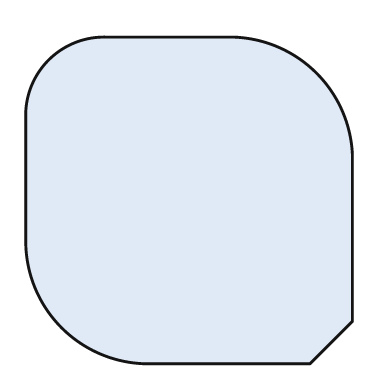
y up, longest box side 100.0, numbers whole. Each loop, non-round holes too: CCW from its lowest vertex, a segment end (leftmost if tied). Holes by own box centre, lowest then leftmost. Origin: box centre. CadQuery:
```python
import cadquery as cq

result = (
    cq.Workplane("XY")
    .moveTo(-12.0, -50.0)
    .lineTo(37.0, -50.0)
    .lineTo(50.0, -37.0)
    .lineTo(50.0, 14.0)
    .threePointArc((39.0, 39.0), (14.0, 50.0))
    .lineTo(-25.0, 50.0)
    .threePointArc((-43.0, 43.0), (-50.0, 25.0))
    .lineTo(-50.0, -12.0)
    .threePointArc((-39.0, -39.0), (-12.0, -50.0))
    .close()
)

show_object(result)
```